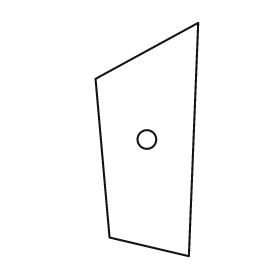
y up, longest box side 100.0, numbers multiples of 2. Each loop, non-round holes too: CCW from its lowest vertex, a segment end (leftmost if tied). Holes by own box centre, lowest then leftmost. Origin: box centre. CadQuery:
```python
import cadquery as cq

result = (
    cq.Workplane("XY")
    .moveTo(18.0, -50.0)
    .lineTo(22.0, 50.0)
    .lineTo(-22.0, 26.0)
    .lineTo(-16.0, -42.0)
    .close()
    .moveTo(0.0, 0.0)
    .circle(4.0)
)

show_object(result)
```